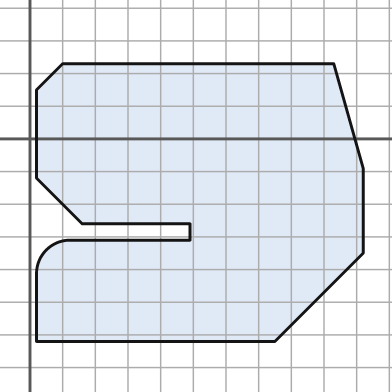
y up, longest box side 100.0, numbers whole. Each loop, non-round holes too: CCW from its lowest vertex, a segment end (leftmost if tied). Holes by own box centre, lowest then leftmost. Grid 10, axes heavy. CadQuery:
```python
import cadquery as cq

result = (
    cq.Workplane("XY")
    .moveTo(2.0, -62.0)
    .lineTo(75.0, -62.0)
    .lineTo(102.0, -35.0)
    .lineTo(102.0, -9.0)
    .lineTo(93.0, 23.0)
    .lineTo(10.0, 23.0)
    .lineTo(2.0, 15.0)
    .lineTo(2.0, -12.0)
    .lineTo(16.0, -26.0)
    .lineTo(49.0, -26.0)
    .lineTo(49.0, -31.0)
    .lineTo(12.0, -31.0)
    .threePointArc((5.0, -34.0), (2.0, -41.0))
    .close()
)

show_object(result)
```